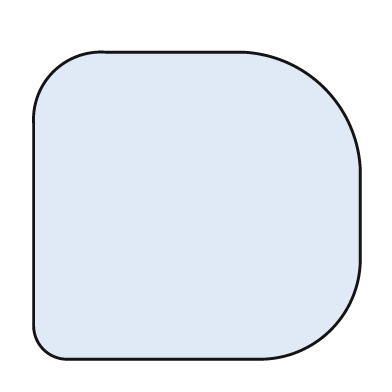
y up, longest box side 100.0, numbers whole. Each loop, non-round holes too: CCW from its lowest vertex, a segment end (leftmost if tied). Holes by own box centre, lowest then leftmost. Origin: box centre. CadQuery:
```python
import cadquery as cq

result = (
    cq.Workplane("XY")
    .moveTo(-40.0, -47.0)
    .lineTo(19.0, -47.0)
    .threePointArc((41.0, -38.0), (50.0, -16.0))
    .lineTo(50.0, 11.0)
    .threePointArc((39.0, 36.0), (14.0, 47.0))
    .lineTo(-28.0, 47.0)
    .threePointArc((-44.0, 41.0), (-50.0, 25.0))
    .lineTo(-50.0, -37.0)
    .threePointArc((-47.0, -44.0), (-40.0, -47.0))
    .close()
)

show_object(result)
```